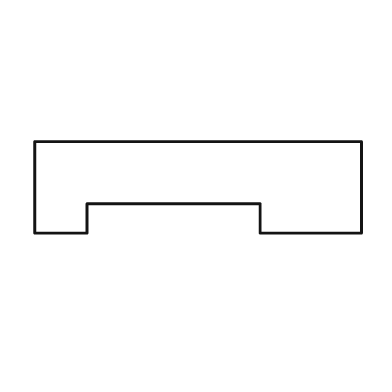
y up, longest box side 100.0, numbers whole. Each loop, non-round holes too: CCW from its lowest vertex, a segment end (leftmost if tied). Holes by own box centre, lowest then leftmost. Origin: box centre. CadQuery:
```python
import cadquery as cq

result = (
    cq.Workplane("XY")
    .moveTo(-50.0, -14.0)
    .lineTo(-34.0, -14.0)
    .lineTo(-34.0, -5.0)
    .lineTo(19.0, -5.0)
    .lineTo(19.0, -14.0)
    .lineTo(50.0, -14.0)
    .lineTo(50.0, 14.0)
    .lineTo(-50.0, 14.0)
    .close()
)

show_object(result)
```